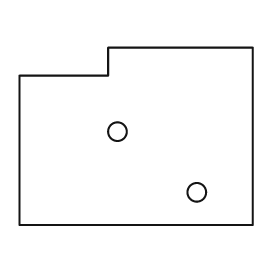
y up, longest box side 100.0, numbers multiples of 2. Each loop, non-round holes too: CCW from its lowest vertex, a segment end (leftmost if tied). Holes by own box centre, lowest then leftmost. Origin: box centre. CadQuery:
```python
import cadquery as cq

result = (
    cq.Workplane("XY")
    .moveTo(-50.0, -38.0)
    .lineTo(50.0, -38.0)
    .lineTo(50.0, 38.0)
    .lineTo(-12.0, 38.0)
    .lineTo(-12.0, 26.0)
    .lineTo(-50.0, 26.0)
    .close()
    .moveTo(26.0, -24.0)
    .circle(4.0)
    .moveTo(-8.0, 2.0)
    .circle(4.0)
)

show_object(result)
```